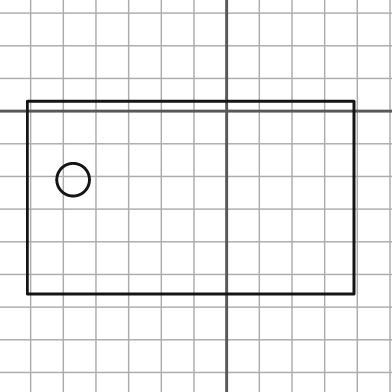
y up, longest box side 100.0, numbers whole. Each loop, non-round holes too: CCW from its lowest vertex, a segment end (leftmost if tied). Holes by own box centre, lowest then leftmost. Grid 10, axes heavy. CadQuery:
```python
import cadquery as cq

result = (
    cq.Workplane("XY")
    .moveTo(-61.0, -56.0)
    .lineTo(39.0, -56.0)
    .lineTo(39.0, 3.0)
    .lineTo(-61.0, 3.0)
    .close()
    .moveTo(-47.0, -21.0)
    .circle(5.0)
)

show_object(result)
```